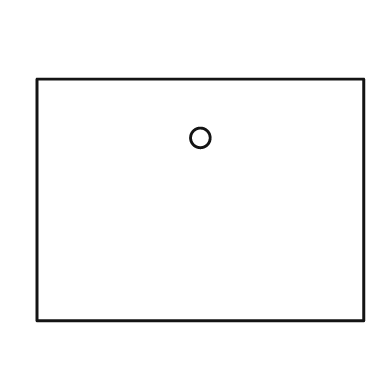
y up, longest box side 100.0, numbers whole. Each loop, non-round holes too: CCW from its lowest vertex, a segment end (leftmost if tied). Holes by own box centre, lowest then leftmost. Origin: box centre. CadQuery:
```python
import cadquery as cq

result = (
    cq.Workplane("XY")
    .moveTo(-50.0, -37.0)
    .lineTo(50.0, -37.0)
    .lineTo(50.0, 37.0)
    .lineTo(-50.0, 37.0)
    .close()
    .moveTo(0.0, 19.0)
    .circle(3.0)
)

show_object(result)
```